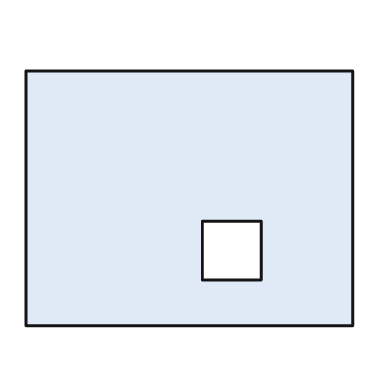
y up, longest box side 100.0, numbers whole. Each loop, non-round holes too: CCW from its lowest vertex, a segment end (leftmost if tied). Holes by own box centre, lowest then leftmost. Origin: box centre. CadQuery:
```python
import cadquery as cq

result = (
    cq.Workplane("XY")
    .moveTo(-50.0, -39.0)
    .lineTo(50.0, -39.0)
    .lineTo(50.0, 39.0)
    .lineTo(-50.0, 39.0)
    .close()
    .moveTo(4.0, -25.0)
    .lineTo(22.0, -25.0)
    .lineTo(22.0, -7.0)
    .lineTo(4.0, -7.0)
    .close()
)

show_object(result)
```